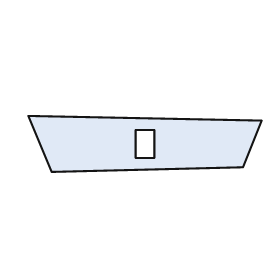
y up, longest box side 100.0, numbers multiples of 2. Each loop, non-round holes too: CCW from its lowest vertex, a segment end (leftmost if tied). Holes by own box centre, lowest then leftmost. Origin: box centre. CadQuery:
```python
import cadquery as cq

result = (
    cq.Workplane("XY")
    .moveTo(-40.0, -12.0)
    .lineTo(42.0, -10.0)
    .lineTo(50.0, 10.0)
    .lineTo(-50.0, 12.0)
    .close()
    .moveTo(-4.0, -6.0)
    .lineTo(4.0, -6.0)
    .lineTo(4.0, 6.0)
    .lineTo(-4.0, 6.0)
    .close()
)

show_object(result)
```